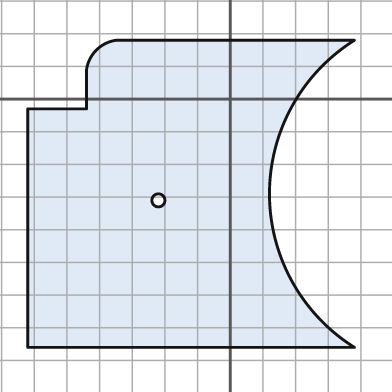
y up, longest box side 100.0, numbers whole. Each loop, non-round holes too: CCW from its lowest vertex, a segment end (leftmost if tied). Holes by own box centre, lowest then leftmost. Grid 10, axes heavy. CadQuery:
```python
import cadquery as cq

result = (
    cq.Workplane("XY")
    .moveTo(-62.0, -76.0)
    .lineTo(38.0, -76.0)
    .threePointArc((12.0, -29.0), (38.0, 18.0))
    .lineTo(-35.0, 18.0)
    .threePointArc((-41.0, 15.0), (-44.0, 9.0))
    .lineTo(-44.0, -3.0)
    .lineTo(-62.0, -3.0)
    .close()
    .moveTo(-22.0, -31.0)
    .circle(2.0)
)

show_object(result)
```